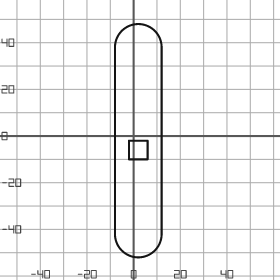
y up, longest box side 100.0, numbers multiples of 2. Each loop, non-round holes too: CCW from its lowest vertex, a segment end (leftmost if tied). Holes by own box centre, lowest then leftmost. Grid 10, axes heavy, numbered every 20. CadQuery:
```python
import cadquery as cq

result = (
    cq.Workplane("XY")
    .moveTo(-8.0, -42.0)
    .threePointArc((2.0, -52.0), (12.0, -42.0))
    .lineTo(12.0, 38.0)
    .threePointArc((2.0, 48.0), (-8.0, 38.0))
    .close()
    .moveTo(-2.0, -10.0)
    .lineTo(6.0, -10.0)
    .lineTo(6.0, -2.0)
    .lineTo(-2.0, -2.0)
    .close()
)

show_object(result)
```